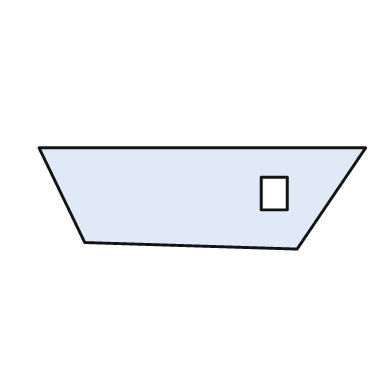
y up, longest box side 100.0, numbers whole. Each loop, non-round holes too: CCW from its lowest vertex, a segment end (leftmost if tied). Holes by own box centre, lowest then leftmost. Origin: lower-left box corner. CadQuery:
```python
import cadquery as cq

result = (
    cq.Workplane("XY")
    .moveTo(79.0, 0.0)
    .lineTo(100.0, 31.0)
    .lineTo(0.0, 31.0)
    .lineTo(14.0, 2.0)
    .close()
    .moveTo(68.0, 12.0)
    .lineTo(76.0, 12.0)
    .lineTo(76.0, 22.0)
    .lineTo(68.0, 22.0)
    .close()
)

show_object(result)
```